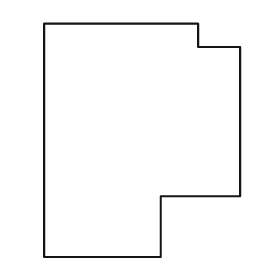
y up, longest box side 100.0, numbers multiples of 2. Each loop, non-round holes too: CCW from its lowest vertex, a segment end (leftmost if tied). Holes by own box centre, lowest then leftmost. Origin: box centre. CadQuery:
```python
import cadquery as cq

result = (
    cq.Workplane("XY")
    .moveTo(-42.0, -50.0)
    .lineTo(8.0, -50.0)
    .lineTo(8.0, -24.0)
    .lineTo(42.0, -24.0)
    .lineTo(42.0, 40.0)
    .lineTo(24.0, 40.0)
    .lineTo(24.0, 50.0)
    .lineTo(-42.0, 50.0)
    .close()
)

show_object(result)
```